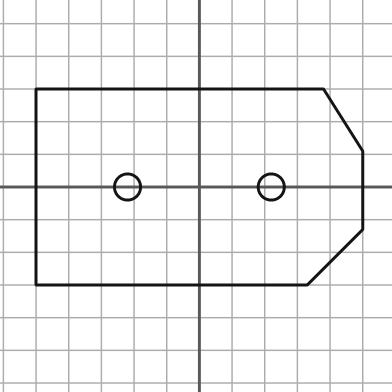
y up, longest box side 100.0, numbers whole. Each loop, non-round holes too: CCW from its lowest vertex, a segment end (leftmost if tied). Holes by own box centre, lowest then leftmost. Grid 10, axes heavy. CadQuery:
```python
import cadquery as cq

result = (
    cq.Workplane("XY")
    .moveTo(-50.0, -30.0)
    .lineTo(33.0, -30.0)
    .lineTo(50.0, -13.0)
    .lineTo(50.0, 11.0)
    .lineTo(38.0, 30.0)
    .lineTo(-50.0, 30.0)
    .close()
    .moveTo(-22.0, 0.0)
    .circle(4.0)
    .moveTo(22.0, 0.0)
    .circle(4.0)
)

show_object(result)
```